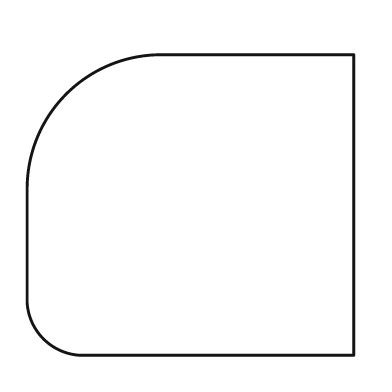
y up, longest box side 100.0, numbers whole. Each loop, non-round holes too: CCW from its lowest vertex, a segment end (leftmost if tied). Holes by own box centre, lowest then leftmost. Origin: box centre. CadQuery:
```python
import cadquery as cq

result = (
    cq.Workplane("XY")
    .moveTo(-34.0, -46.0)
    .lineTo(50.0, -46.0)
    .lineTo(50.0, 46.0)
    .lineTo(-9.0, 46.0)
    .threePointArc((-38.0, 34.0), (-50.0, 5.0))
    .lineTo(-50.0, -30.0)
    .threePointArc((-45.0, -41.0), (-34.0, -46.0))
    .close()
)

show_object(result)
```